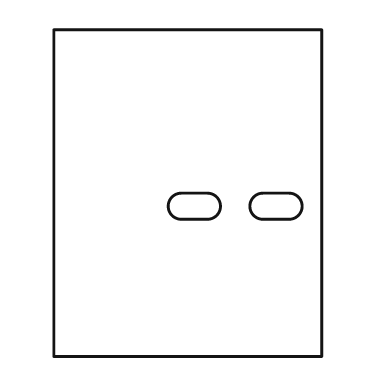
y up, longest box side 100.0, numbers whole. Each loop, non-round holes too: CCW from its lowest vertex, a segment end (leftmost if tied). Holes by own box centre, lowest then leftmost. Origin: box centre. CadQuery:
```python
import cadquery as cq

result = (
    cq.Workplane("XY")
    .moveTo(-41.0, -50.0)
    .lineTo(41.0, -50.0)
    .lineTo(41.0, 50.0)
    .lineTo(-41.0, 50.0)
    .close()
    .moveTo(-2.0, -8.0)
    .lineTo(6.0, -8.0)
    .threePointArc((10.0, -4.0), (6.0, 0.0))
    .lineTo(-2.0, 0.0)
    .threePointArc((-6.0, -4.0), (-2.0, -8.0))
    .close()
    .moveTo(23.0, -8.0)
    .lineTo(31.0, -8.0)
    .threePointArc((35.0, -4.0), (31.0, 0.0))
    .lineTo(23.0, 0.0)
    .threePointArc((19.0, -4.0), (23.0, -8.0))
    .close()
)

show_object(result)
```